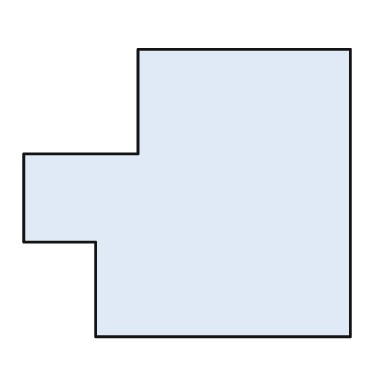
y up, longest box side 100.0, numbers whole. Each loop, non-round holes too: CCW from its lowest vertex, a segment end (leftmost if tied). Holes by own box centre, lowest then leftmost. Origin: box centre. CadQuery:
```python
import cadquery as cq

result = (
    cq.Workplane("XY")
    .moveTo(-28.0, -44.0)
    .lineTo(50.0, -44.0)
    .lineTo(50.0, 44.0)
    .lineTo(-15.0, 44.0)
    .lineTo(-15.0, 12.0)
    .lineTo(-50.0, 12.0)
    .lineTo(-50.0, -15.0)
    .lineTo(-28.0, -15.0)
    .close()
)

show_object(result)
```